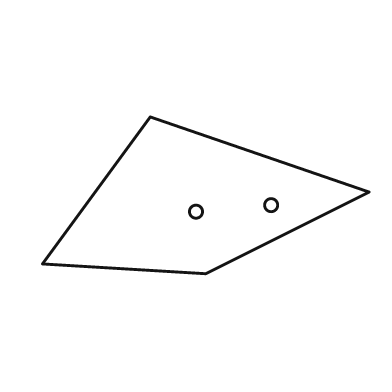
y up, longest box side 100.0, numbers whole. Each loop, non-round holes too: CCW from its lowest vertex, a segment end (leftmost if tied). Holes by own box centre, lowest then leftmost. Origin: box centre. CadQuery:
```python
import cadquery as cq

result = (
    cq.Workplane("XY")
    .moveTo(0.0, -24.0)
    .lineTo(50.0, 1.0)
    .lineTo(-17.0, 24.0)
    .lineTo(-50.0, -21.0)
    .close()
    .moveTo(-3.0, -5.0)
    .circle(2.0)
    .moveTo(20.0, -3.0)
    .circle(2.0)
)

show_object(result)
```